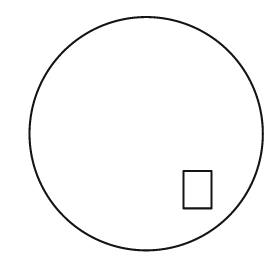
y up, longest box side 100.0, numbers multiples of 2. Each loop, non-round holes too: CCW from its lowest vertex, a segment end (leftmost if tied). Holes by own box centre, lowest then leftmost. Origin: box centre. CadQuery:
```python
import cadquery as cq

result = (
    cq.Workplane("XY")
    .moveTo(0.0, 0.0)
    .circle(50.0)
    .moveTo(16.0, -32.0)
    .lineTo(28.0, -32.0)
    .lineTo(28.0, -16.0)
    .lineTo(16.0, -16.0)
    .close()
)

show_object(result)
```